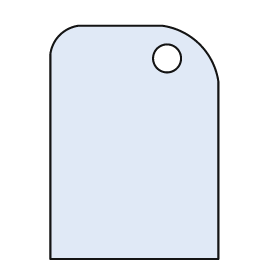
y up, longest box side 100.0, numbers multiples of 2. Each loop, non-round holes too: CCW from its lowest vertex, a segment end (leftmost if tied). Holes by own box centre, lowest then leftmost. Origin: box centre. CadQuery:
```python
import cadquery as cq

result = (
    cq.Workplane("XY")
    .moveTo(-36.0, -50.0)
    .lineTo(36.0, -50.0)
    .lineTo(36.0, 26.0)
    .threePointArc((28.0, 42.0), (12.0, 50.0))
    .lineTo(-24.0, 50.0)
    .threePointArc((-32.0, 46.0), (-36.0, 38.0))
    .close()
    .moveTo(14.0, 36.0)
    .circle(6.0)
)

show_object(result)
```